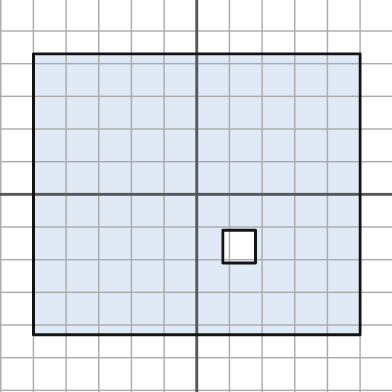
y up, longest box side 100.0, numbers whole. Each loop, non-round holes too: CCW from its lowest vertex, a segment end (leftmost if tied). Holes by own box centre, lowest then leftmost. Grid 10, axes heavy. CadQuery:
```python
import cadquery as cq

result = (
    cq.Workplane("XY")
    .moveTo(-50.0, -43.0)
    .lineTo(50.0, -43.0)
    .lineTo(50.0, 43.0)
    .lineTo(-50.0, 43.0)
    .close()
    .moveTo(8.0, -21.0)
    .lineTo(18.0, -21.0)
    .lineTo(18.0, -11.0)
    .lineTo(8.0, -11.0)
    .close()
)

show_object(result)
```